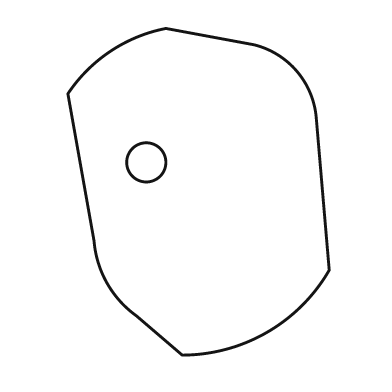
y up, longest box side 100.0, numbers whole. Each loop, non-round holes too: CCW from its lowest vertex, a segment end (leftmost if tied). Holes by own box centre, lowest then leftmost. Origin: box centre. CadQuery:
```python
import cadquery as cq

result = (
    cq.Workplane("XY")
    .moveTo(-5.0, -50.0)
    .threePointArc((21.0, -43.0), (40.0, -24.0))
    .lineTo(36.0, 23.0)
    .threePointArc((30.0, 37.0), (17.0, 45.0))
    .lineTo(-10.0, 50.0)
    .threePointArc((-27.0, 43.0), (-40.0, 30.0))
    .lineTo(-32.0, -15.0)
    .threePointArc((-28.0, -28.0), (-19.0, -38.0))
    .close()
    .moveTo(-16.0, 9.0)
    .circle(6.0)
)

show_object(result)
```